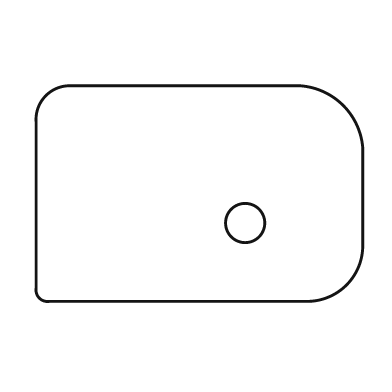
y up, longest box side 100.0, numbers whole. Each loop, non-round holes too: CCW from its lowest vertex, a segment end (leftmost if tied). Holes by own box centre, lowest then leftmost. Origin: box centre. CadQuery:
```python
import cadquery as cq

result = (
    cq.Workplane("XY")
    .moveTo(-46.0, -33.0)
    .lineTo(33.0, -33.0)
    .threePointArc((45.0, -28.0), (50.0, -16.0))
    .lineTo(50.0, 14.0)
    .threePointArc((44.0, 27.0), (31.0, 33.0))
    .lineTo(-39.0, 33.0)
    .threePointArc((-47.0, 30.0), (-50.0, 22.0))
    .lineTo(-50.0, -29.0)
    .threePointArc((-49.0, -32.0), (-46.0, -33.0))
    .close()
    .moveTo(14.0, -9.0)
    .circle(6.0)
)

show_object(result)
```